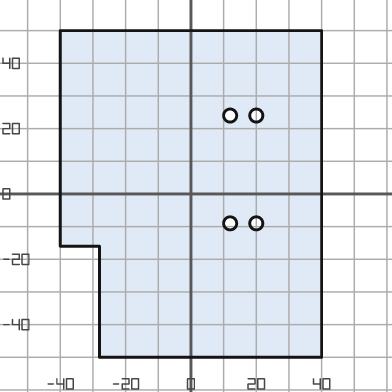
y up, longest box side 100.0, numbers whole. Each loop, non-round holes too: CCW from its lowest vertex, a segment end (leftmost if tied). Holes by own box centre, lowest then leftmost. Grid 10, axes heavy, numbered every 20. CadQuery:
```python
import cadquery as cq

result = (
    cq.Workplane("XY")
    .moveTo(-28.0, -50.0)
    .lineTo(40.0, -50.0)
    .lineTo(40.0, 50.0)
    .lineTo(-40.0, 50.0)
    .lineTo(-40.0, -16.0)
    .lineTo(-28.0, -16.0)
    .close()
    .moveTo(12.0, -9.0)
    .circle(2.0)
    .moveTo(20.0, -9.0)
    .circle(2.0)
    .moveTo(12.0, 24.0)
    .circle(2.0)
    .moveTo(20.0, 24.0)
    .circle(2.0)
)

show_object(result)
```